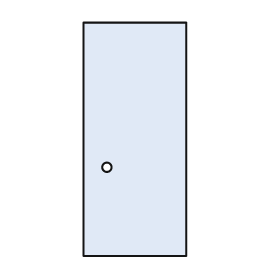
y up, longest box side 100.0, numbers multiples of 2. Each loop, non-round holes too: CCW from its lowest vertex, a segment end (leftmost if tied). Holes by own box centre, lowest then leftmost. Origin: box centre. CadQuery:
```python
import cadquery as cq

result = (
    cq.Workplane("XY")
    .moveTo(-22.0, -50.0)
    .lineTo(22.0, -50.0)
    .lineTo(22.0, 50.0)
    .lineTo(-22.0, 50.0)
    .close()
    .moveTo(-12.0, -12.0)
    .circle(2.0)
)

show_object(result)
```